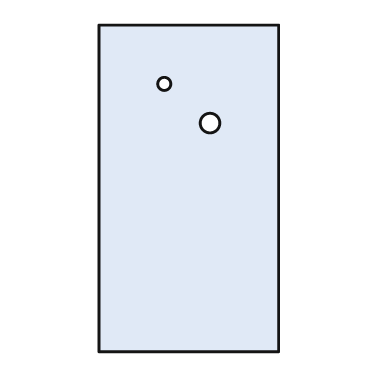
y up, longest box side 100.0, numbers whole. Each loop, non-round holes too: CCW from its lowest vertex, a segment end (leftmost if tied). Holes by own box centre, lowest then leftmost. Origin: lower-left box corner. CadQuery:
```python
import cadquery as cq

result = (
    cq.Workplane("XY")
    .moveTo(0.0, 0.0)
    .lineTo(55.0, 0.0)
    .lineTo(55.0, 100.0)
    .lineTo(0.0, 100.0)
    .close()
    .moveTo(34.0, 70.0)
    .circle(3.0)
    .moveTo(20.0, 82.0)
    .circle(2.0)
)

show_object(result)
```